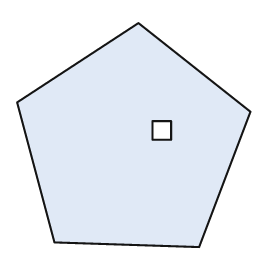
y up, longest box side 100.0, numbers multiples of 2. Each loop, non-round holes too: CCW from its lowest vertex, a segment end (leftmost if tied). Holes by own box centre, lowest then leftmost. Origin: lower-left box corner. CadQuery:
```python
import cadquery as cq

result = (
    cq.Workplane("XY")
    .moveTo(78.0, 0.0)
    .lineTo(100.0, 58.0)
    .lineTo(52.0, 96.0)
    .lineTo(0.0, 62.0)
    .lineTo(16.0, 2.0)
    .close()
    .moveTo(58.0, 46.0)
    .lineTo(66.0, 46.0)
    .lineTo(66.0, 54.0)
    .lineTo(58.0, 54.0)
    .close()
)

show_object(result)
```